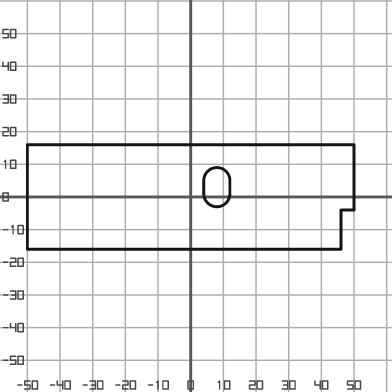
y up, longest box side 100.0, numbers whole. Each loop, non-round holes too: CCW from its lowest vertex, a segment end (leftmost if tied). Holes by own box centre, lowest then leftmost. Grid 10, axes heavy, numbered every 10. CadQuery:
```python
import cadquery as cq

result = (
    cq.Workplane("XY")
    .moveTo(-50.0, -16.0)
    .lineTo(46.0, -16.0)
    .lineTo(46.0, -4.0)
    .lineTo(50.0, -4.0)
    .lineTo(50.0, 16.0)
    .lineTo(-50.0, 16.0)
    .close()
    .moveTo(4.0, 1.0)
    .threePointArc((8.0, -3.0), (12.0, 1.0))
    .lineTo(12.0, 5.0)
    .threePointArc((8.0, 9.0), (4.0, 5.0))
    .close()
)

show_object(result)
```